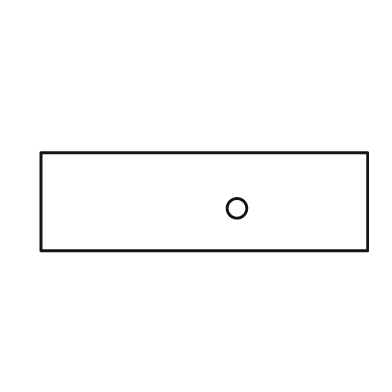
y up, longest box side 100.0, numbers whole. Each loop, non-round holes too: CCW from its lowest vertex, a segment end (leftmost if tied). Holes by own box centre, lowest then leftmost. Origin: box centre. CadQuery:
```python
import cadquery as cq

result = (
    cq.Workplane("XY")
    .moveTo(-50.0, -15.0)
    .lineTo(50.0, -15.0)
    .lineTo(50.0, 15.0)
    .lineTo(-50.0, 15.0)
    .close()
    .moveTo(10.0, -2.0)
    .circle(3.0)
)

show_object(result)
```